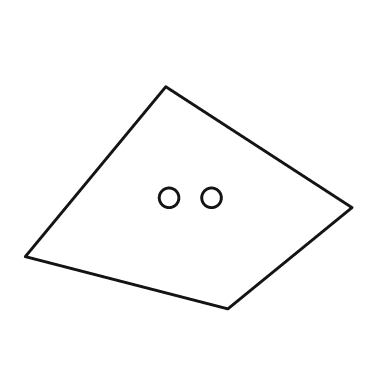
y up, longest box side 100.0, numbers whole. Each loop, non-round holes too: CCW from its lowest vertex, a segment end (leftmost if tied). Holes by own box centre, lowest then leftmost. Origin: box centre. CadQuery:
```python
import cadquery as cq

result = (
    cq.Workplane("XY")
    .moveTo(12.0, -34.0)
    .lineTo(50.0, -3.0)
    .lineTo(-7.0, 34.0)
    .lineTo(-50.0, -18.0)
    .close()
    .moveTo(-6.0, 0.0)
    .circle(3.0)
    .moveTo(7.0, 0.0)
    .circle(3.0)
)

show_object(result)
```